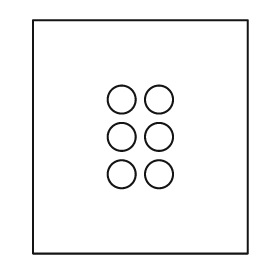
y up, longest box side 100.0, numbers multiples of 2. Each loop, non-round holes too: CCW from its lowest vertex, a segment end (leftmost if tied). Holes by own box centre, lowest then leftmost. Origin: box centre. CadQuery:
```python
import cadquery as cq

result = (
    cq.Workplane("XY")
    .moveTo(-46.0, -50.0)
    .lineTo(46.0, -50.0)
    .lineTo(46.0, 50.0)
    .lineTo(-46.0, 50.0)
    .close()
    .moveTo(-8.0, -16.0)
    .circle(6.0)
    .moveTo(8.0, -16.0)
    .circle(6.0)
    .moveTo(-8.0, 0.0)
    .circle(6.0)
    .moveTo(8.0, 0.0)
    .circle(6.0)
    .moveTo(-8.0, 16.0)
    .circle(6.0)
    .moveTo(8.0, 16.0)
    .circle(6.0)
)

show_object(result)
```